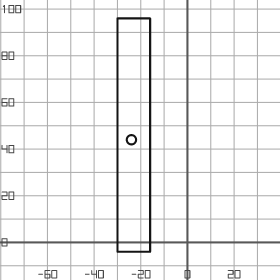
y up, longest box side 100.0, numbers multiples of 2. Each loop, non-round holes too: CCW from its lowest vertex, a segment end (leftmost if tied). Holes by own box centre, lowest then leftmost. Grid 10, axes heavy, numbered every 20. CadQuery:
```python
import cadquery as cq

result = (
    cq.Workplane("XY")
    .moveTo(-30.0, -4.0)
    .lineTo(-16.0, -4.0)
    .lineTo(-16.0, 96.0)
    .lineTo(-30.0, 96.0)
    .close()
    .moveTo(-24.0, 44.0)
    .circle(2.0)
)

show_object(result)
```